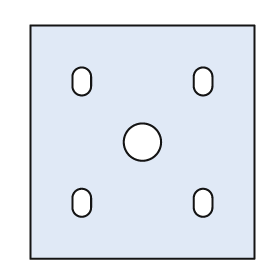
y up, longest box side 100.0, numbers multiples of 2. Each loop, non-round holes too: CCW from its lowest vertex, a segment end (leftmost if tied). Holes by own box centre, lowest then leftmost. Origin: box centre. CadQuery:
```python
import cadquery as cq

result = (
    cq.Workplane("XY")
    .moveTo(-48.0, -50.0)
    .lineTo(48.0, -50.0)
    .lineTo(48.0, 50.0)
    .lineTo(-48.0, 50.0)
    .close()
    .moveTo(-30.0, -28.0)
    .threePointArc((-26.0, -32.0), (-22.0, -28.0))
    .lineTo(-22.0, -24.0)
    .threePointArc((-26.0, -20.0), (-30.0, -24.0))
    .close()
    .moveTo(22.0, -28.0)
    .threePointArc((26.0, -32.0), (30.0, -28.0))
    .lineTo(30.0, -24.0)
    .threePointArc((26.0, -20.0), (22.0, -24.0))
    .close()
    .moveTo(0.0, 0.0)
    .circle(8.0)
    .moveTo(-30.0, 24.0)
    .threePointArc((-26.0, 20.0), (-22.0, 24.0))
    .lineTo(-22.0, 28.0)
    .threePointArc((-26.0, 32.0), (-30.0, 28.0))
    .close()
    .moveTo(22.0, 24.0)
    .threePointArc((26.0, 20.0), (30.0, 24.0))
    .lineTo(30.0, 28.0)
    .threePointArc((26.0, 32.0), (22.0, 28.0))
    .close()
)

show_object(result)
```